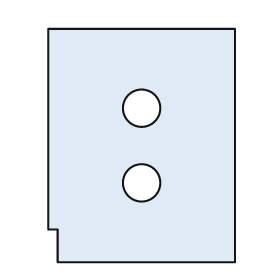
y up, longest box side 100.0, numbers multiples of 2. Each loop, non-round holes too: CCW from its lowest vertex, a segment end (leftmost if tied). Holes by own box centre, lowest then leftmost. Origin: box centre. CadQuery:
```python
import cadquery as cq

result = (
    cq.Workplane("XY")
    .moveTo(-36.0, -50.0)
    .lineTo(40.0, -50.0)
    .lineTo(40.0, 50.0)
    .lineTo(-40.0, 50.0)
    .lineTo(-40.0, -36.0)
    .lineTo(-36.0, -36.0)
    .close()
    .moveTo(0.0, -16.0)
    .circle(8.0)
    .moveTo(0.0, 16.0)
    .circle(8.0)
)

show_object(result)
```